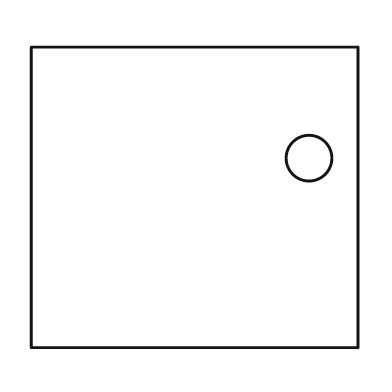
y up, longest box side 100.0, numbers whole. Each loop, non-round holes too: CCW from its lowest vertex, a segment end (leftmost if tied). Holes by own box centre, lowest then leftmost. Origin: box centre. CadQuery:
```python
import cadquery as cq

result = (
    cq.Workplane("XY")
    .moveTo(-50.0, -46.0)
    .lineTo(50.0, -46.0)
    .lineTo(50.0, 46.0)
    .lineTo(-50.0, 46.0)
    .close()
    .moveTo(35.0, 12.0)
    .circle(7.0)
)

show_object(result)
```